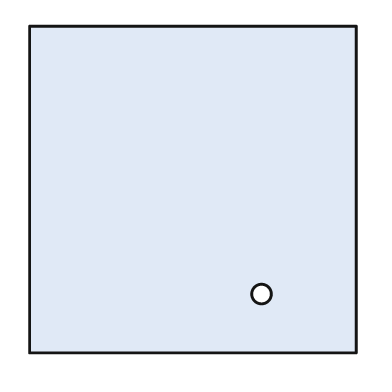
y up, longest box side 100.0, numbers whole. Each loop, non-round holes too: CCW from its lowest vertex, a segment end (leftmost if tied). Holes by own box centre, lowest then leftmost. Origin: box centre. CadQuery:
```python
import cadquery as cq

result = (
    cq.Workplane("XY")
    .moveTo(-50.0, -50.0)
    .lineTo(50.0, -50.0)
    .lineTo(50.0, 50.0)
    .lineTo(-50.0, 50.0)
    .close()
    .moveTo(21.0, -32.0)
    .circle(3.0)
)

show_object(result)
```